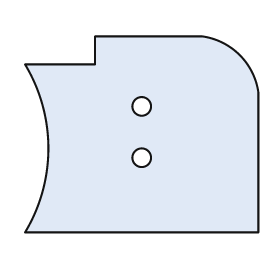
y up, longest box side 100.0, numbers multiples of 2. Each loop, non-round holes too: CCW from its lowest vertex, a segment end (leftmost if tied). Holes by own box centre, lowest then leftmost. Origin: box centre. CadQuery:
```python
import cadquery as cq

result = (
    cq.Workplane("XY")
    .moveTo(-50.0, -42.0)
    .lineTo(50.0, -42.0)
    .lineTo(50.0, 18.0)
    .threePointArc((42.0, 34.0), (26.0, 42.0))
    .lineTo(-20.0, 42.0)
    .lineTo(-20.0, 30.0)
    .lineTo(-50.0, 30.0)
    .threePointArc((-40.0, -6.0), (-50.0, -42.0))
    .close()
    .moveTo(0.0, -10.0)
    .circle(4.0)
    .moveTo(0.0, 12.0)
    .circle(4.0)
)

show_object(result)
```